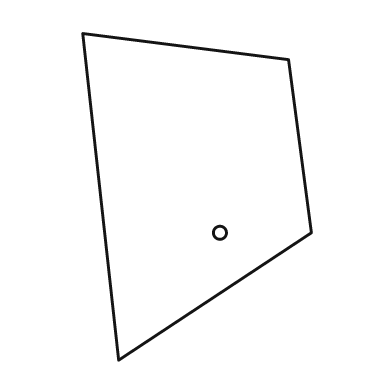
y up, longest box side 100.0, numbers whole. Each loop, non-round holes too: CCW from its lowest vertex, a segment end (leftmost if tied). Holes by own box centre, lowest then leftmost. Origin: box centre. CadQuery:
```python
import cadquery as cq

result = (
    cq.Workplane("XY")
    .moveTo(-24.0, -50.0)
    .lineTo(35.0, -11.0)
    .lineTo(28.0, 42.0)
    .lineTo(-35.0, 50.0)
    .close()
    .moveTo(7.0, -11.0)
    .circle(2.0)
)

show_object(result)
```